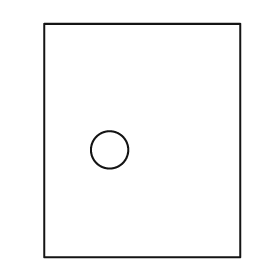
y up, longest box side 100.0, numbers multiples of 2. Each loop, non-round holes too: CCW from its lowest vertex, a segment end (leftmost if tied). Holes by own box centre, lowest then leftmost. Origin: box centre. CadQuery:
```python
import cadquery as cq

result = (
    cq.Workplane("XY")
    .moveTo(-42.0, -50.0)
    .lineTo(42.0, -50.0)
    .lineTo(42.0, 50.0)
    .lineTo(-42.0, 50.0)
    .close()
    .moveTo(-14.0, -4.0)
    .circle(8.0)
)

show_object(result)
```